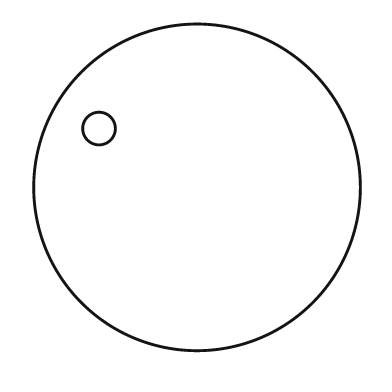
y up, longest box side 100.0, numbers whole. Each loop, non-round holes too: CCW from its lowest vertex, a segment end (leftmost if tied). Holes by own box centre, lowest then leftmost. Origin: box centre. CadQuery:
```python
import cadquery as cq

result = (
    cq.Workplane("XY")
    .moveTo(0.0, 0.0)
    .circle(50.0)
    .moveTo(-30.0, 18.0)
    .circle(5.0)
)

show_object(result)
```